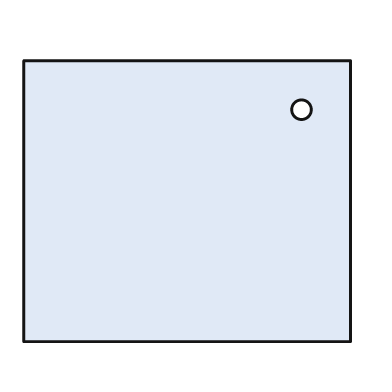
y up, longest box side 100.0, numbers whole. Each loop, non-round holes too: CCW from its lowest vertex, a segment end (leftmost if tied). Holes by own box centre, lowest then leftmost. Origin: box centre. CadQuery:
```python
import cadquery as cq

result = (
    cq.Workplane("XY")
    .moveTo(-50.0, -43.0)
    .lineTo(50.0, -43.0)
    .lineTo(50.0, 43.0)
    .lineTo(-50.0, 43.0)
    .close()
    .moveTo(35.0, 28.0)
    .circle(3.0)
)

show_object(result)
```